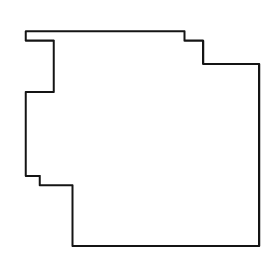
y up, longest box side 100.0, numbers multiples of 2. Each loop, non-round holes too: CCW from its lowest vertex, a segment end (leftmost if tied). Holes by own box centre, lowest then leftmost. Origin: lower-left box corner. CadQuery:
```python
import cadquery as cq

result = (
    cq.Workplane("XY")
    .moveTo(20.0, 0.0)
    .lineTo(100.0, 0.0)
    .lineTo(100.0, 78.0)
    .lineTo(76.0, 78.0)
    .lineTo(76.0, 88.0)
    .lineTo(68.0, 88.0)
    .lineTo(68.0, 92.0)
    .lineTo(0.0, 92.0)
    .lineTo(0.0, 88.0)
    .lineTo(12.0, 88.0)
    .lineTo(12.0, 66.0)
    .lineTo(0.0, 66.0)
    .lineTo(0.0, 30.0)
    .lineTo(6.0, 30.0)
    .lineTo(6.0, 26.0)
    .lineTo(20.0, 26.0)
    .close()
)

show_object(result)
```